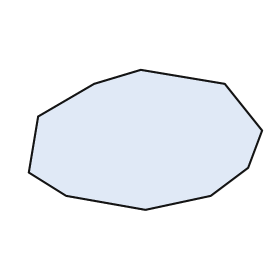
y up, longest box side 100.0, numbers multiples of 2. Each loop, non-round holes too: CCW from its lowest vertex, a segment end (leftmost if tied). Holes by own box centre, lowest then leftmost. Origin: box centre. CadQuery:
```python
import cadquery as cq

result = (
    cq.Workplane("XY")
    .moveTo(0.0, -30.0)
    .lineTo(28.0, -24.0)
    .lineTo(44.0, -12.0)
    .lineTo(50.0, 4.0)
    .lineTo(34.0, 24.0)
    .lineTo(-2.0, 30.0)
    .lineTo(-22.0, 24.0)
    .lineTo(-46.0, 10.0)
    .lineTo(-50.0, -14.0)
    .lineTo(-34.0, -24.0)
    .close()
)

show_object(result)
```